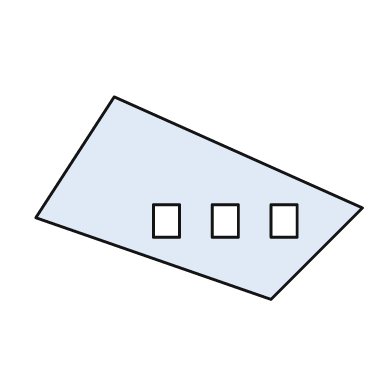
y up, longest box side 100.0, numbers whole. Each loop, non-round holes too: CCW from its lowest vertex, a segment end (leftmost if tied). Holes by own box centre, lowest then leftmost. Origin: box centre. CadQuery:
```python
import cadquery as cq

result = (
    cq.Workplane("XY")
    .moveTo(22.0, -31.0)
    .lineTo(50.0, -3.0)
    .lineTo(-26.0, 31.0)
    .lineTo(-50.0, -6.0)
    .close()
    .moveTo(-14.0, -12.0)
    .lineTo(-6.0, -12.0)
    .lineTo(-6.0, -2.0)
    .lineTo(-14.0, -2.0)
    .close()
    .moveTo(4.0, -12.0)
    .lineTo(12.0, -12.0)
    .lineTo(12.0, -2.0)
    .lineTo(4.0, -2.0)
    .close()
    .moveTo(22.0, -12.0)
    .lineTo(30.0, -12.0)
    .lineTo(30.0, -2.0)
    .lineTo(22.0, -2.0)
    .close()
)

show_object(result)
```